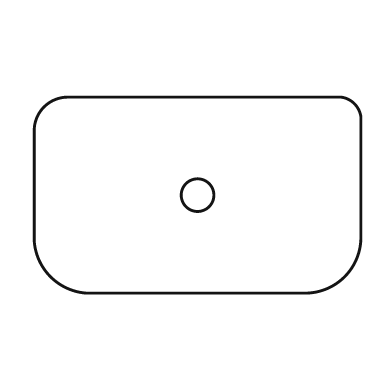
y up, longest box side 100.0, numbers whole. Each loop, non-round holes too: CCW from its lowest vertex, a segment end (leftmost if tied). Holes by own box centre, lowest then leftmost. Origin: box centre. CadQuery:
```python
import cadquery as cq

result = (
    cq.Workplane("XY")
    .moveTo(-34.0, -30.0)
    .lineTo(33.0, -30.0)
    .threePointArc((45.0, -25.0), (50.0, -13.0))
    .lineTo(50.0, 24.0)
    .threePointArc((48.0, 28.0), (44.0, 30.0))
    .lineTo(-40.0, 30.0)
    .threePointArc((-47.0, 27.0), (-50.0, 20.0))
    .lineTo(-50.0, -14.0)
    .threePointArc((-45.0, -25.0), (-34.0, -30.0))
    .close()
    .moveTo(0.0, 0.0)
    .circle(5.0)
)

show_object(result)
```